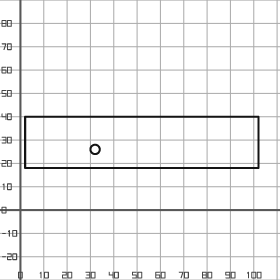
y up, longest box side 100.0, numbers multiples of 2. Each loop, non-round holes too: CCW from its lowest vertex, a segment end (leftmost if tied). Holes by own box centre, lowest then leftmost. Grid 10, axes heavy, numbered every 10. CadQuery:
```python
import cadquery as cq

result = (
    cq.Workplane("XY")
    .moveTo(2.0, 18.0)
    .lineTo(102.0, 18.0)
    .lineTo(102.0, 40.0)
    .lineTo(2.0, 40.0)
    .close()
    .moveTo(32.0, 26.0)
    .circle(2.0)
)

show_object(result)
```